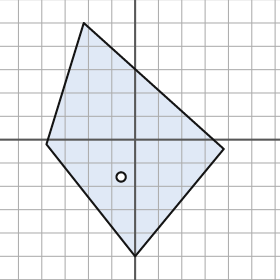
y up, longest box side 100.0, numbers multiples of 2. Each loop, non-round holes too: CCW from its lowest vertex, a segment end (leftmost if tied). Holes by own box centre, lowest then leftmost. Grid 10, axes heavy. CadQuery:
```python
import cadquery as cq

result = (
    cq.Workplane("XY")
    .moveTo(0.0, -50.0)
    .lineTo(38.0, -4.0)
    .lineTo(-22.0, 50.0)
    .lineTo(-38.0, -2.0)
    .close()
    .moveTo(-6.0, -16.0)
    .circle(2.0)
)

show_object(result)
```